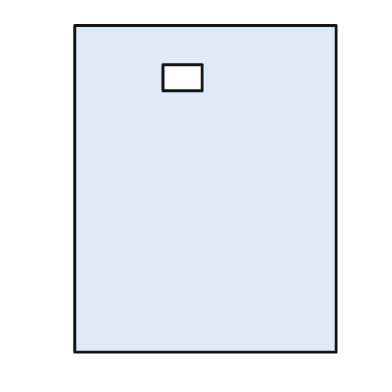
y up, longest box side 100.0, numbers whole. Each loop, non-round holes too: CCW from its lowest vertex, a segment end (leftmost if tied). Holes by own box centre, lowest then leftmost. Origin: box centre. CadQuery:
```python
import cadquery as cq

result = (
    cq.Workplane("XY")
    .moveTo(-40.0, -50.0)
    .lineTo(40.0, -50.0)
    .lineTo(40.0, 50.0)
    .lineTo(-40.0, 50.0)
    .close()
    .moveTo(-13.0, 30.0)
    .lineTo(-1.0, 30.0)
    .lineTo(-1.0, 38.0)
    .lineTo(-13.0, 38.0)
    .close()
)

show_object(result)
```